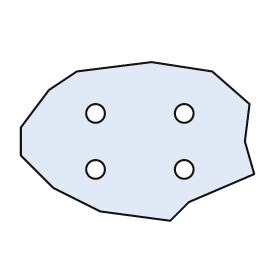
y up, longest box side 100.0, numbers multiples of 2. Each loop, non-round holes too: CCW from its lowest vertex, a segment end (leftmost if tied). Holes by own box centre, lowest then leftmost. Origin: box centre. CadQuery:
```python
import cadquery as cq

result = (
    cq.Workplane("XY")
    .moveTo(14.0, -34.0)
    .lineTo(22.0, -26.0)
    .lineTo(50.0, -14.0)
    .lineTo(46.0, 0.0)
    .lineTo(48.0, 16.0)
    .lineTo(32.0, 30.0)
    .lineTo(6.0, 34.0)
    .lineTo(-26.0, 30.0)
    .lineTo(-38.0, 22.0)
    .lineTo(-50.0, 6.0)
    .lineTo(-50.0, -6.0)
    .lineTo(-36.0, -20.0)
    .lineTo(-16.0, -30.0)
    .close()
    .moveTo(-18.0, -12.0)
    .circle(4.0)
    .moveTo(20.0, -12.0)
    .circle(4.0)
    .moveTo(-18.0, 12.0)
    .circle(4.0)
    .moveTo(20.0, 12.0)
    .circle(4.0)
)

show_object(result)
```